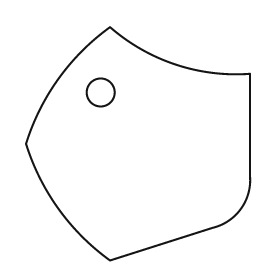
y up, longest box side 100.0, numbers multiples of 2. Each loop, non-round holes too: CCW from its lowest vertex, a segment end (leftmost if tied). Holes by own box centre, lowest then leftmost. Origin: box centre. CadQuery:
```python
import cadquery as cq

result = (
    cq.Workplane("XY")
    .moveTo(-12.0, -50.0)
    .lineTo(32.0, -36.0)
    .threePointArc((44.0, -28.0), (48.0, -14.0))
    .lineTo(48.0, 30.0)
    .threePointArc((16.0, 34.0), (-12.0, 50.0))
    .threePointArc((-34.0, 28.0), (-48.0, 0.0))
    .threePointArc((-34.0, -28.0), (-12.0, -50.0))
    .close()
    .moveTo(-16.0, 22.0)
    .circle(6.0)
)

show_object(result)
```